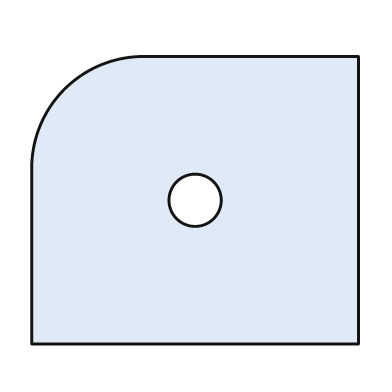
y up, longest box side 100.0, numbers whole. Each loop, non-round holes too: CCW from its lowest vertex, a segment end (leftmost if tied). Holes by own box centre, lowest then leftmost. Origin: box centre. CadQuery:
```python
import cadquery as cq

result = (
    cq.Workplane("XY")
    .moveTo(-50.0, -44.0)
    .lineTo(50.0, -44.0)
    .lineTo(50.0, 44.0)
    .lineTo(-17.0, 44.0)
    .threePointArc((-40.0, 34.0), (-50.0, 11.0))
    .close()
    .moveTo(0.0, 0.0)
    .circle(8.0)
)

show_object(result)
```